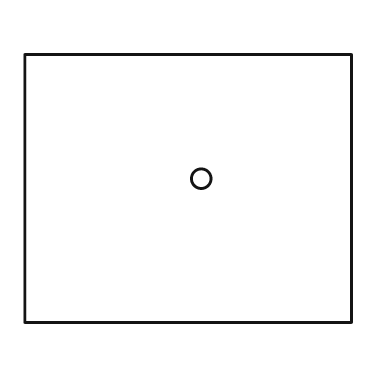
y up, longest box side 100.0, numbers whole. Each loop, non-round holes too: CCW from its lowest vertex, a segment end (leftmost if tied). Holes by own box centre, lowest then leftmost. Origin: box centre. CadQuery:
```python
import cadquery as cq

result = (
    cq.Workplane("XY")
    .moveTo(-50.0, -41.0)
    .lineTo(50.0, -41.0)
    .lineTo(50.0, 41.0)
    .lineTo(-50.0, 41.0)
    .close()
    .moveTo(4.0, 3.0)
    .circle(3.0)
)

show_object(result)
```